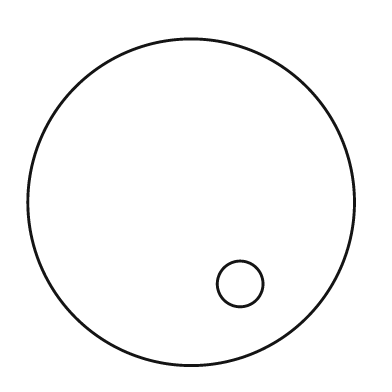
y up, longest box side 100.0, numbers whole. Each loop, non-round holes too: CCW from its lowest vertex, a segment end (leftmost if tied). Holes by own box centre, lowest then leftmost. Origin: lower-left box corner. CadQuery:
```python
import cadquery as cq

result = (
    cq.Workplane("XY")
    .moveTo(50.0, 50.0)
    .circle(50.0)
    .moveTo(65.0, 25.0)
    .circle(7.0)
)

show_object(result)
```